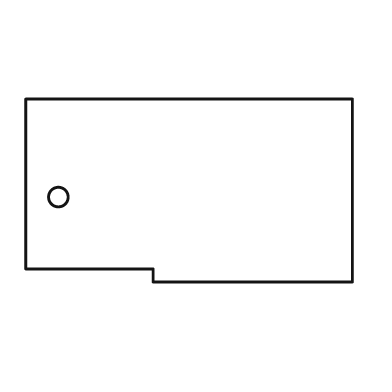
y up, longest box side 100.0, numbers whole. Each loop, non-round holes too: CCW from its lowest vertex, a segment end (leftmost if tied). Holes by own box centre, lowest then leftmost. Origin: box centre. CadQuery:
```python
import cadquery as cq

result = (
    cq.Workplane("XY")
    .moveTo(-11.0, -28.0)
    .lineTo(50.0, -28.0)
    .lineTo(50.0, 28.0)
    .lineTo(-50.0, 28.0)
    .lineTo(-50.0, -24.0)
    .lineTo(-11.0, -24.0)
    .close()
    .moveTo(-40.0, -2.0)
    .circle(3.0)
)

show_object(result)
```